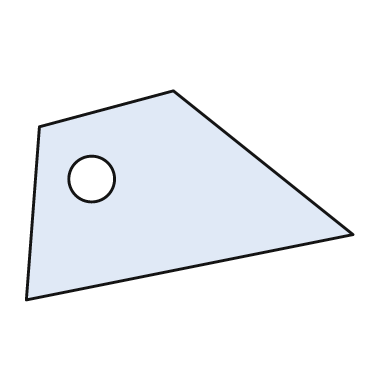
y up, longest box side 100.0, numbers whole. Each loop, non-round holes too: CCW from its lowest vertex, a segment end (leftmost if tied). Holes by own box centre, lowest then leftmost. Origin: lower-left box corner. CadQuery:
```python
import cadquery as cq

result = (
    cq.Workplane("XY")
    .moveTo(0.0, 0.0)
    .lineTo(100.0, 20.0)
    .lineTo(45.0, 64.0)
    .lineTo(4.0, 53.0)
    .close()
    .moveTo(20.0, 37.0)
    .circle(7.0)
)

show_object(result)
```